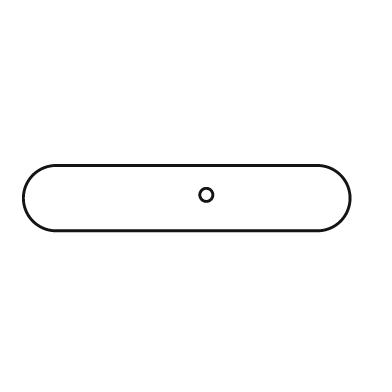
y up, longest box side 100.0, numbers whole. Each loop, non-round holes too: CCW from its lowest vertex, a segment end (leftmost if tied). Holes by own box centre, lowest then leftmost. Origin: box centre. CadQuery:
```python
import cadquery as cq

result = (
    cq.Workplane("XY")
    .moveTo(-40.0, -10.0)
    .lineTo(40.0, -10.0)
    .threePointArc((50.0, 0.0), (40.0, 10.0))
    .lineTo(-40.0, 10.0)
    .threePointArc((-50.0, 0.0), (-40.0, -10.0))
    .close()
    .moveTo(6.0, 1.0)
    .circle(2.0)
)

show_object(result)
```